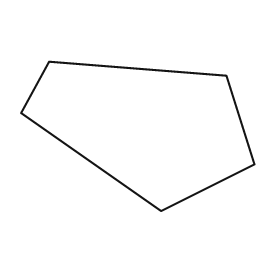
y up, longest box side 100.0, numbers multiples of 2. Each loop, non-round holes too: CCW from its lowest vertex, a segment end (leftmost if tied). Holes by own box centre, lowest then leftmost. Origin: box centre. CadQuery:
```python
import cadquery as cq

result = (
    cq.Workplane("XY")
    .moveTo(10.0, -32.0)
    .lineTo(50.0, -12.0)
    .lineTo(38.0, 26.0)
    .lineTo(-38.0, 32.0)
    .lineTo(-50.0, 10.0)
    .close()
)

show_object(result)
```